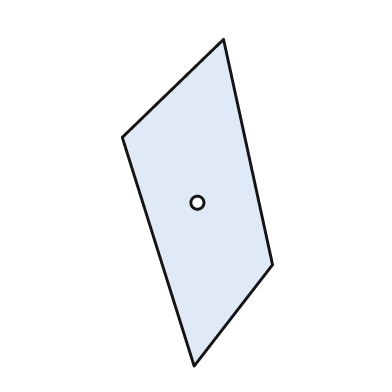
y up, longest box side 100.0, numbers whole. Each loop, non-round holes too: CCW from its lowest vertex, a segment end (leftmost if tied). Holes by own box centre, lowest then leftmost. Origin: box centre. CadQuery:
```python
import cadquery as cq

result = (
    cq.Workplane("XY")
    .moveTo(-1.0, -50.0)
    .lineTo(23.0, -19.0)
    .lineTo(8.0, 50.0)
    .lineTo(-23.0, 20.0)
    .close()
    .moveTo(0.0, 0.0)
    .circle(2.0)
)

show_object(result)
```